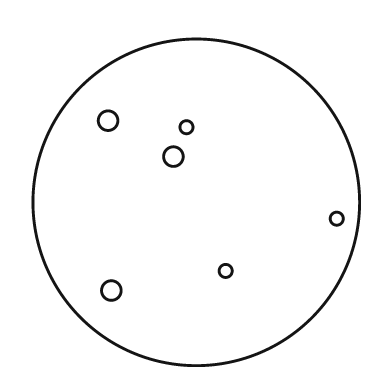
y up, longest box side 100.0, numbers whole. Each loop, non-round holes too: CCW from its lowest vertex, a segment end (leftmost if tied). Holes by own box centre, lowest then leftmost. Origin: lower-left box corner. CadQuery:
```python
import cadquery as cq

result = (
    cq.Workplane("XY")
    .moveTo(50.0, 50.0)
    .circle(50.0)
    .moveTo(24.0, 23.0)
    .circle(3.0)
    .moveTo(59.0, 29.0)
    .circle(2.0)
    .moveTo(93.0, 45.0)
    .circle(2.0)
    .moveTo(43.0, 64.0)
    .circle(3.0)
    .moveTo(47.0, 73.0)
    .circle(2.0)
    .moveTo(23.0, 75.0)
    .circle(3.0)
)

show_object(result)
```